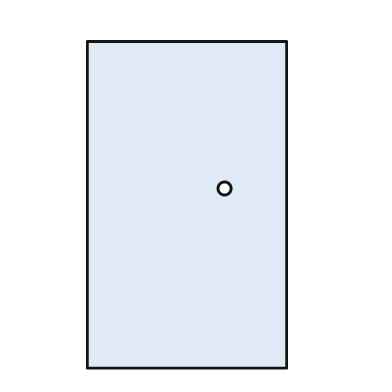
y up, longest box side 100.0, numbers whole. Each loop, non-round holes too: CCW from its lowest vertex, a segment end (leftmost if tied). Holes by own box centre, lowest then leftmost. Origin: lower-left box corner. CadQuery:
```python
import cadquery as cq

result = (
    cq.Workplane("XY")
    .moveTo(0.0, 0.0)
    .lineTo(61.0, 0.0)
    .lineTo(61.0, 100.0)
    .lineTo(0.0, 100.0)
    .close()
    .moveTo(42.0, 55.0)
    .circle(2.0)
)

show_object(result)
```